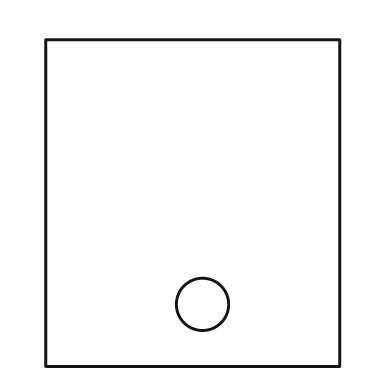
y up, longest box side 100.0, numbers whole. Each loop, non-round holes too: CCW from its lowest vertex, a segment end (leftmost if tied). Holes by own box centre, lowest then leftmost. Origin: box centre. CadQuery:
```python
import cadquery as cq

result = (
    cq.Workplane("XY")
    .moveTo(-45.0, -50.0)
    .lineTo(45.0, -50.0)
    .lineTo(45.0, 50.0)
    .lineTo(-45.0, 50.0)
    .close()
    .moveTo(3.0, -31.0)
    .circle(8.0)
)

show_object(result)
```